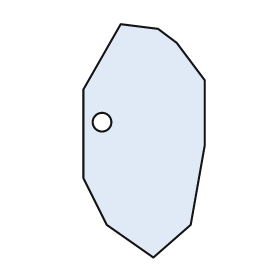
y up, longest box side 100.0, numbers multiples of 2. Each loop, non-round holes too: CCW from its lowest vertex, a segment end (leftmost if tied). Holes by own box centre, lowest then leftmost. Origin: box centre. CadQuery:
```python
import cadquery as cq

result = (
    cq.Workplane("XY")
    .moveTo(4.0, -50.0)
    .lineTo(20.0, -36.0)
    .lineTo(26.0, -2.0)
    .lineTo(26.0, 26.0)
    .lineTo(14.0, 42.0)
    .lineTo(6.0, 48.0)
    .lineTo(-10.0, 50.0)
    .lineTo(-26.0, 22.0)
    .lineTo(-26.0, -16.0)
    .lineTo(-16.0, -36.0)
    .close()
    .moveTo(-18.0, 8.0)
    .circle(4.0)
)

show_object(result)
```